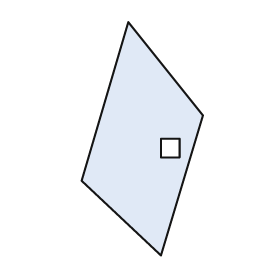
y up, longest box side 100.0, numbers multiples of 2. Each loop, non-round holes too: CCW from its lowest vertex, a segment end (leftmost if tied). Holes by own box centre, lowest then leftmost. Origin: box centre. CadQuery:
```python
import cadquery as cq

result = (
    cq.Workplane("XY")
    .moveTo(8.0, -50.0)
    .lineTo(26.0, 10.0)
    .lineTo(-6.0, 50.0)
    .lineTo(-26.0, -18.0)
    .close()
    .moveTo(8.0, -8.0)
    .lineTo(16.0, -8.0)
    .lineTo(16.0, 0.0)
    .lineTo(8.0, 0.0)
    .close()
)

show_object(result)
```